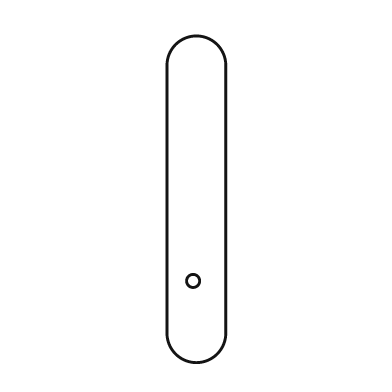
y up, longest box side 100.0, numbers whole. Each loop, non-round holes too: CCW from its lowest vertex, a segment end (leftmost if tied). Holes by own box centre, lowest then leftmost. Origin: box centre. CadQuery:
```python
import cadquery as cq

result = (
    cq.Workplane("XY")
    .moveTo(-9.0, -41.0)
    .threePointArc((0.0, -50.0), (9.0, -41.0))
    .lineTo(9.0, 41.0)
    .threePointArc((0.0, 50.0), (-9.0, 41.0))
    .close()
    .moveTo(-1.0, -25.0)
    .circle(2.0)
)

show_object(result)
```